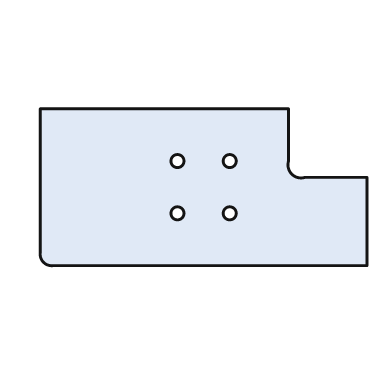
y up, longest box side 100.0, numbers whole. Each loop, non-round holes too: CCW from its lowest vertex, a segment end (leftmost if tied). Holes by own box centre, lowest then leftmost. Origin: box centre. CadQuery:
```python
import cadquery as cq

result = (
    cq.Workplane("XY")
    .moveTo(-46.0, -24.0)
    .lineTo(50.0, -24.0)
    .lineTo(50.0, 3.0)
    .lineTo(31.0, 3.0)
    .threePointArc((27.0, 4.0), (26.0, 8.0))
    .lineTo(26.0, 24.0)
    .lineTo(-50.0, 24.0)
    .lineTo(-50.0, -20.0)
    .threePointArc((-49.0, -23.0), (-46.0, -24.0))
    .close()
    .moveTo(-8.0, -8.0)
    .circle(2.0)
    .moveTo(8.0, -8.0)
    .circle(2.0)
    .moveTo(-8.0, 8.0)
    .circle(2.0)
    .moveTo(8.0, 8.0)
    .circle(2.0)
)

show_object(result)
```